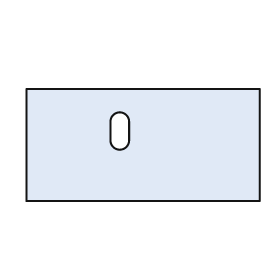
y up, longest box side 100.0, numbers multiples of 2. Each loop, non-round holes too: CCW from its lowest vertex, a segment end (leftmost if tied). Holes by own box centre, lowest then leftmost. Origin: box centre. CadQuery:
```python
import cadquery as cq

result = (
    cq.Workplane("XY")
    .moveTo(-50.0, -24.0)
    .lineTo(50.0, -24.0)
    .lineTo(50.0, 24.0)
    .lineTo(-50.0, 24.0)
    .close()
    .moveTo(-14.0, 2.0)
    .threePointArc((-10.0, -2.0), (-6.0, 2.0))
    .lineTo(-6.0, 10.0)
    .threePointArc((-10.0, 14.0), (-14.0, 10.0))
    .close()
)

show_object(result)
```